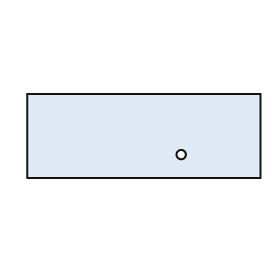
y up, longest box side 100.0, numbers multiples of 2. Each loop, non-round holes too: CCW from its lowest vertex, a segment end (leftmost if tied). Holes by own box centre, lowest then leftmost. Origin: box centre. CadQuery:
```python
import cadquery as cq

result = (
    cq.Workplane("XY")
    .moveTo(-50.0, -18.0)
    .lineTo(50.0, -18.0)
    .lineTo(50.0, 18.0)
    .lineTo(-50.0, 18.0)
    .close()
    .moveTo(16.0, -8.0)
    .circle(2.0)
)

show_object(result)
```